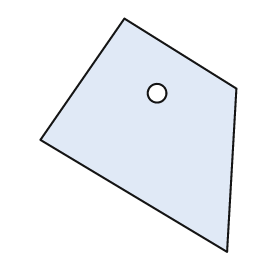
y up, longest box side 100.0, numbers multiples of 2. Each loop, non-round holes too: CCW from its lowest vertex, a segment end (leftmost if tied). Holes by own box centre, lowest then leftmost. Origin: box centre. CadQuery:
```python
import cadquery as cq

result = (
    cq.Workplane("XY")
    .moveTo(38.0, -50.0)
    .lineTo(42.0, 20.0)
    .lineTo(-6.0, 50.0)
    .lineTo(-42.0, -2.0)
    .close()
    .moveTo(8.0, 18.0)
    .circle(4.0)
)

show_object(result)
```